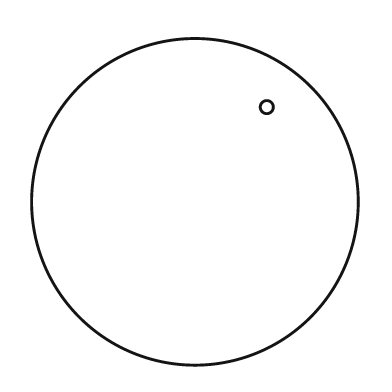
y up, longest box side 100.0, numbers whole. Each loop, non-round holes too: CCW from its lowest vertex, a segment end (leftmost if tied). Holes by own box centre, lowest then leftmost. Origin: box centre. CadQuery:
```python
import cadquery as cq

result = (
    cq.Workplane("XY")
    .moveTo(0.0, 0.0)
    .circle(50.0)
    .moveTo(22.0, 29.0)
    .circle(2.0)
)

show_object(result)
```